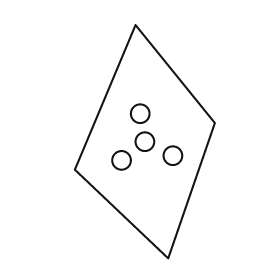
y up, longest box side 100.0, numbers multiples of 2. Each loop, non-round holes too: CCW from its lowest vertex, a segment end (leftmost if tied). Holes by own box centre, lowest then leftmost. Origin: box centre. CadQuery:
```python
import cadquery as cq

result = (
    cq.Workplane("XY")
    .moveTo(10.0, -50.0)
    .lineTo(30.0, 8.0)
    .lineTo(-4.0, 50.0)
    .lineTo(-30.0, -12.0)
    .close()
    .moveTo(-10.0, -8.0)
    .circle(4.0)
    .moveTo(12.0, -6.0)
    .circle(4.0)
    .moveTo(0.0, 0.0)
    .circle(4.0)
    .moveTo(-2.0, 12.0)
    .circle(4.0)
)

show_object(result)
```